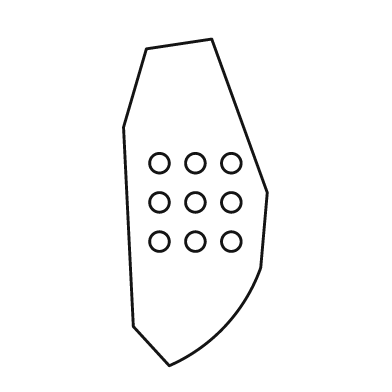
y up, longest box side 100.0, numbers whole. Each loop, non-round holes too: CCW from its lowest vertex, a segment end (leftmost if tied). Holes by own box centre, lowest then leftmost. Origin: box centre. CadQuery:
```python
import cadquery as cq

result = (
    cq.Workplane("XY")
    .moveTo(-8.0, -50.0)
    .threePointArc((9.0, -38.0), (20.0, -20.0))
    .lineTo(22.0, 3.0)
    .lineTo(5.0, 50.0)
    .lineTo(-15.0, 47.0)
    .lineTo(-22.0, 23.0)
    .lineTo(-19.0, -38.0)
    .close()
    .moveTo(-11.0, -12.0)
    .circle(3.0)
    .moveTo(0.0, -12.0)
    .circle(3.0)
    .moveTo(11.0, -12.0)
    .circle(3.0)
    .moveTo(-11.0, 0.0)
    .circle(3.0)
    .moveTo(0.0, 0.0)
    .circle(3.0)
    .moveTo(11.0, 0.0)
    .circle(3.0)
    .moveTo(-11.0, 12.0)
    .circle(3.0)
    .moveTo(0.0, 12.0)
    .circle(3.0)
    .moveTo(11.0, 12.0)
    .circle(3.0)
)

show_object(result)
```